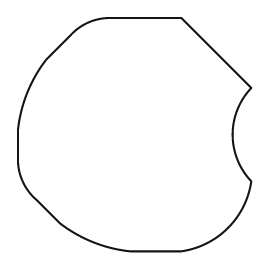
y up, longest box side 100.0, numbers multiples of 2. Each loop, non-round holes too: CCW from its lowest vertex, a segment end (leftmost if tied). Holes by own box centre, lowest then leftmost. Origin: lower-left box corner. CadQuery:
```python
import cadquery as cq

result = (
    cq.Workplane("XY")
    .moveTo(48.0, 0.0)
    .lineTo(70.0, 0.0)
    .threePointArc((90.0, 10.0), (100.0, 30.0))
    .threePointArc((92.0, 50.0), (100.0, 70.0))
    .lineTo(70.0, 100.0)
    .lineTo(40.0, 100.0)
    .threePointArc((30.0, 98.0), (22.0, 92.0))
    .lineTo(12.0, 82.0)
    .threePointArc((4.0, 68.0), (0.0, 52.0))
    .lineTo(0.0, 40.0)
    .threePointArc((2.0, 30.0), (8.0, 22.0))
    .lineTo(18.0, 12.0)
    .threePointArc((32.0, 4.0), (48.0, 0.0))
    .close()
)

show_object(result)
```